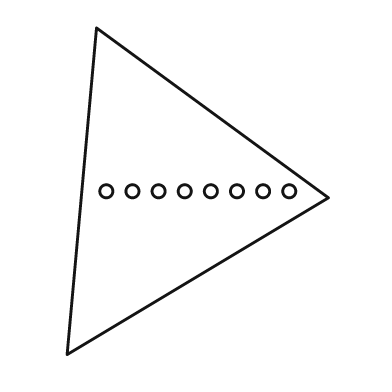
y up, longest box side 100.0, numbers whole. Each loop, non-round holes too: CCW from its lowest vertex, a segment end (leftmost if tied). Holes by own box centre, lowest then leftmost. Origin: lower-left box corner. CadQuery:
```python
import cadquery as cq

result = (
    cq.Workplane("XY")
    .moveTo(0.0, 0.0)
    .lineTo(80.0, 48.0)
    .lineTo(9.0, 100.0)
    .close()
    .moveTo(12.0, 50.0)
    .circle(2.0)
    .moveTo(20.0, 50.0)
    .circle(2.0)
    .moveTo(28.0, 50.0)
    .circle(2.0)
    .moveTo(36.0, 50.0)
    .circle(2.0)
    .moveTo(44.0, 50.0)
    .circle(2.0)
    .moveTo(52.0, 50.0)
    .circle(2.0)
    .moveTo(60.0, 50.0)
    .circle(2.0)
    .moveTo(68.0, 50.0)
    .circle(2.0)
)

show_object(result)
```